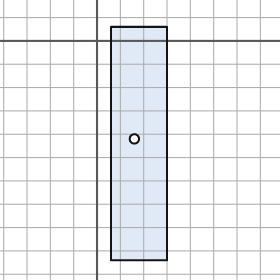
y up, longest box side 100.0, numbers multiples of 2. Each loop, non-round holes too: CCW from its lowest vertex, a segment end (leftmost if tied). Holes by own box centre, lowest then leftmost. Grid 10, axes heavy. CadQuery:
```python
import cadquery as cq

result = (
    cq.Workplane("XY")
    .moveTo(6.0, -94.0)
    .lineTo(30.0, -94.0)
    .lineTo(30.0, 6.0)
    .lineTo(6.0, 6.0)
    .close()
    .moveTo(16.0, -42.0)
    .circle(2.0)
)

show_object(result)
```